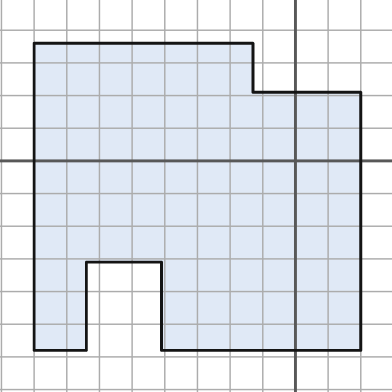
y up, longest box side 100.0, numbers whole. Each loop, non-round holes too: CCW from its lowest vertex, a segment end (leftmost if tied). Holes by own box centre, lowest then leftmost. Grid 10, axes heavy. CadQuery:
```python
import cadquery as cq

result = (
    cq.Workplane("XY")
    .moveTo(-80.0, -58.0)
    .lineTo(-64.0, -58.0)
    .lineTo(-64.0, -31.0)
    .lineTo(-41.0, -31.0)
    .lineTo(-41.0, -58.0)
    .lineTo(20.0, -58.0)
    .lineTo(20.0, 21.0)
    .lineTo(-13.0, 21.0)
    .lineTo(-13.0, 36.0)
    .lineTo(-80.0, 36.0)
    .close()
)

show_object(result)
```